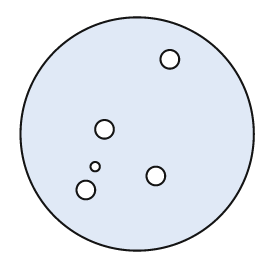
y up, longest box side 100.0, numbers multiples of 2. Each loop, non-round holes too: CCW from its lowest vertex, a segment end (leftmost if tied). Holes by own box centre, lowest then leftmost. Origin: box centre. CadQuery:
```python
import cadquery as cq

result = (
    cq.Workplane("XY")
    .moveTo(0.0, 0.0)
    .circle(50.0)
    .moveTo(-22.0, -24.0)
    .circle(4.0)
    .moveTo(8.0, -18.0)
    .circle(4.0)
    .moveTo(-18.0, -14.0)
    .circle(2.0)
    .moveTo(-14.0, 2.0)
    .circle(4.0)
    .moveTo(14.0, 32.0)
    .circle(4.0)
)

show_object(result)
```